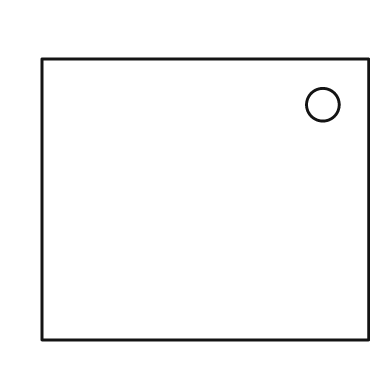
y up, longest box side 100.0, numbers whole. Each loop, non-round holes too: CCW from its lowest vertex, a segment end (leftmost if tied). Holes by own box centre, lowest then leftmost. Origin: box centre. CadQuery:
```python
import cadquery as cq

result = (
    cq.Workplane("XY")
    .moveTo(-50.0, -43.0)
    .lineTo(50.0, -43.0)
    .lineTo(50.0, 43.0)
    .lineTo(-50.0, 43.0)
    .close()
    .moveTo(36.0, 29.0)
    .circle(5.0)
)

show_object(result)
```